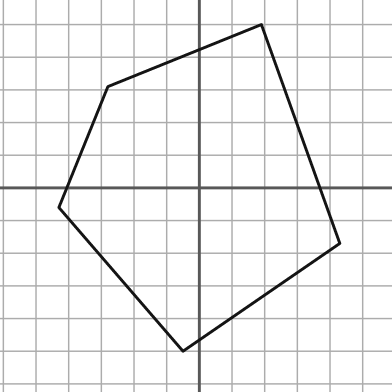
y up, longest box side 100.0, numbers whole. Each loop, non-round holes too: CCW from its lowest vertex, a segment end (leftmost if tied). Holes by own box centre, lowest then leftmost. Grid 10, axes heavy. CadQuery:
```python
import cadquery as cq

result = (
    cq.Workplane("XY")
    .moveTo(-5.0, -50.0)
    .lineTo(43.0, -17.0)
    .lineTo(19.0, 50.0)
    .lineTo(-28.0, 31.0)
    .lineTo(-43.0, -6.0)
    .close()
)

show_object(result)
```